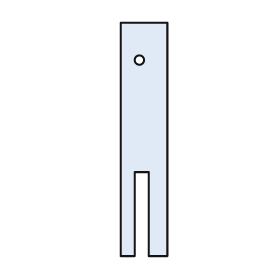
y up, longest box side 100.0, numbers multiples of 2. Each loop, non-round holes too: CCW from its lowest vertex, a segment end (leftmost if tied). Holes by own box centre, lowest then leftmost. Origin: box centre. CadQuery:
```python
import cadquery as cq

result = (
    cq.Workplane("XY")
    .moveTo(-10.0, -50.0)
    .lineTo(-4.0, -50.0)
    .lineTo(-4.0, -14.0)
    .lineTo(2.0, -14.0)
    .lineTo(2.0, -50.0)
    .lineTo(10.0, -50.0)
    .lineTo(10.0, 50.0)
    .lineTo(-10.0, 50.0)
    .close()
    .moveTo(-2.0, 34.0)
    .circle(2.0)
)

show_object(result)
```